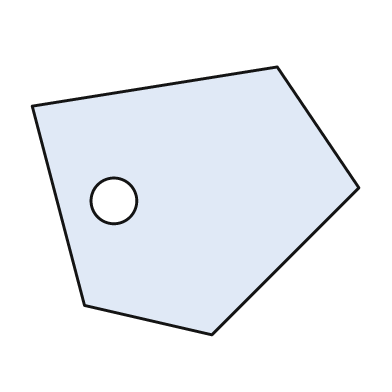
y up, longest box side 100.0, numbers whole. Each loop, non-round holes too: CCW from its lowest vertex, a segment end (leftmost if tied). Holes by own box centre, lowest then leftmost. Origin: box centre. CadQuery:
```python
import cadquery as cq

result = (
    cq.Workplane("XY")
    .moveTo(5.0, -41.0)
    .lineTo(50.0, 4.0)
    .lineTo(25.0, 41.0)
    .lineTo(-50.0, 29.0)
    .lineTo(-34.0, -32.0)
    .close()
    .moveTo(-25.0, 0.0)
    .circle(7.0)
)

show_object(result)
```